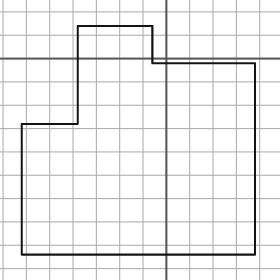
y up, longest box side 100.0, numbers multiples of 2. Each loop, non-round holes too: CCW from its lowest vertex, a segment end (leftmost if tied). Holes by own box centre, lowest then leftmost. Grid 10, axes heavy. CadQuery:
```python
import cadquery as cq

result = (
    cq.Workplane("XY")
    .moveTo(-62.0, -84.0)
    .lineTo(38.0, -84.0)
    .lineTo(38.0, -2.0)
    .lineTo(-6.0, -2.0)
    .lineTo(-6.0, 14.0)
    .lineTo(-38.0, 14.0)
    .lineTo(-38.0, -28.0)
    .lineTo(-62.0, -28.0)
    .close()
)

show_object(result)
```